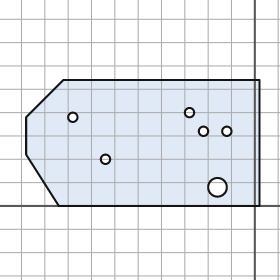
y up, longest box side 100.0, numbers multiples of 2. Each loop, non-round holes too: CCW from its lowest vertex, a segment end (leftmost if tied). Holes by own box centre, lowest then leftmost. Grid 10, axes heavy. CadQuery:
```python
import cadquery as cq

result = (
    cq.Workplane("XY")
    .moveTo(-84.0, 0.0)
    .lineTo(2.0, 0.0)
    .lineTo(2.0, 54.0)
    .lineTo(-82.0, 54.0)
    .lineTo(-98.0, 38.0)
    .lineTo(-98.0, 22.0)
    .close()
    .moveTo(-16.0, 8.0)
    .circle(4.0)
    .moveTo(-64.0, 20.0)
    .circle(2.0)
    .moveTo(-22.0, 32.0)
    .circle(2.0)
    .moveTo(-12.0, 32.0)
    .circle(2.0)
    .moveTo(-78.0, 38.0)
    .circle(2.0)
    .moveTo(-28.0, 40.0)
    .circle(2.0)
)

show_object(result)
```